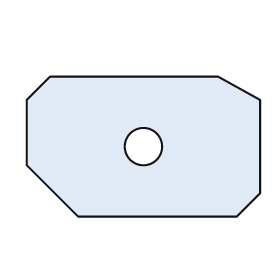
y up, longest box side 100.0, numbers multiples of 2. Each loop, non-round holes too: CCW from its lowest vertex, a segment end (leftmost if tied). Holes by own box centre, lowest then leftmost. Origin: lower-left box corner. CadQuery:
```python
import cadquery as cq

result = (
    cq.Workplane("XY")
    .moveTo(22.0, 0.0)
    .lineTo(90.0, 0.0)
    .lineTo(100.0, 10.0)
    .lineTo(100.0, 50.0)
    .lineTo(82.0, 60.0)
    .lineTo(10.0, 60.0)
    .lineTo(0.0, 50.0)
    .lineTo(0.0, 22.0)
    .close()
    .moveTo(50.0, 30.0)
    .circle(8.0)
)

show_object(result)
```